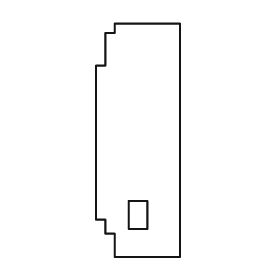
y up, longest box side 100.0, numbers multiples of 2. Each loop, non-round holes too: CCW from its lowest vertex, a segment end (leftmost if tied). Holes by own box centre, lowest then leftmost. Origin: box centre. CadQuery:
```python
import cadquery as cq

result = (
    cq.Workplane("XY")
    .moveTo(-10.0, -50.0)
    .lineTo(18.0, -50.0)
    .lineTo(18.0, 50.0)
    .lineTo(-10.0, 50.0)
    .lineTo(-10.0, 46.0)
    .lineTo(-14.0, 46.0)
    .lineTo(-14.0, 32.0)
    .lineTo(-18.0, 32.0)
    .lineTo(-18.0, -34.0)
    .lineTo(-14.0, -34.0)
    .lineTo(-14.0, -40.0)
    .lineTo(-10.0, -40.0)
    .close()
    .moveTo(-4.0, -38.0)
    .lineTo(4.0, -38.0)
    .lineTo(4.0, -26.0)
    .lineTo(-4.0, -26.0)
    .close()
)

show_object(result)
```